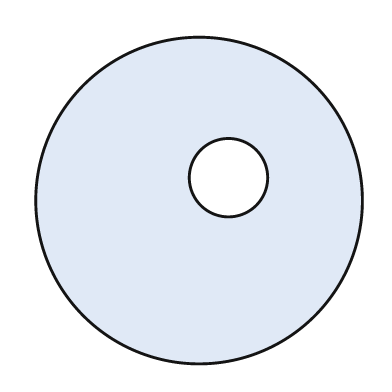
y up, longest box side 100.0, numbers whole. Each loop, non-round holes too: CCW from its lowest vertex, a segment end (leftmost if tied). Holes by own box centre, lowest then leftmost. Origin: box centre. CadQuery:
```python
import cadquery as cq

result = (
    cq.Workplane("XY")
    .moveTo(0.0, 0.0)
    .circle(50.0)
    .moveTo(9.0, 7.0)
    .circle(12.0)
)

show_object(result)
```